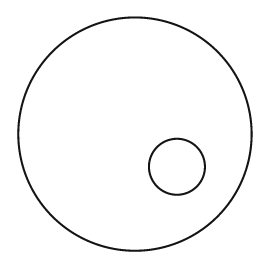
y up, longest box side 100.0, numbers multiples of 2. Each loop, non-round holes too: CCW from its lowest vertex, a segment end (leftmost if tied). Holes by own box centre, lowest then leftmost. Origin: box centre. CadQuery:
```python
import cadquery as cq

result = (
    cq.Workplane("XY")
    .moveTo(0.0, 0.0)
    .circle(50.0)
    .moveTo(18.0, -14.0)
    .circle(12.0)
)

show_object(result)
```